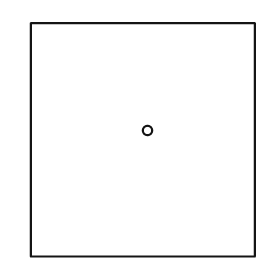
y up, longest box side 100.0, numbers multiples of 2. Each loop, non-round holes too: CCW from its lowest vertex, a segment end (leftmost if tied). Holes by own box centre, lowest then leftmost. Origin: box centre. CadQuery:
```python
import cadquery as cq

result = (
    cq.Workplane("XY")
    .moveTo(-48.0, -50.0)
    .lineTo(48.0, -50.0)
    .lineTo(48.0, 50.0)
    .lineTo(-48.0, 50.0)
    .close()
    .moveTo(2.0, 4.0)
    .circle(2.0)
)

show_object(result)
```